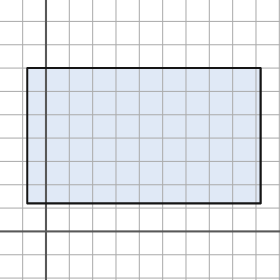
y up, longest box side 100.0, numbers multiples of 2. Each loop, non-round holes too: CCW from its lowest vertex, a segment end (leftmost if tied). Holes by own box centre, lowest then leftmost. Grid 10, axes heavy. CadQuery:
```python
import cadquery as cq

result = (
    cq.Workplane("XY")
    .moveTo(-8.0, 12.0)
    .lineTo(92.0, 12.0)
    .lineTo(92.0, 70.0)
    .lineTo(-8.0, 70.0)
    .close()
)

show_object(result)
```